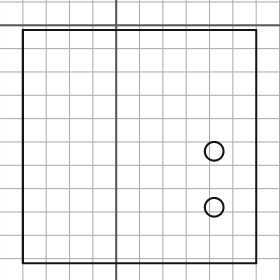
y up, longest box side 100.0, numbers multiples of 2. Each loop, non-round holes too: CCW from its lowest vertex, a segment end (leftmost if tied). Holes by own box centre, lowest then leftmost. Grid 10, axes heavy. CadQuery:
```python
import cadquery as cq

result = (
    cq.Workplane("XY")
    .moveTo(-40.0, -102.0)
    .lineTo(60.0, -102.0)
    .lineTo(60.0, -2.0)
    .lineTo(-40.0, -2.0)
    .close()
    .moveTo(42.0, -78.0)
    .circle(4.0)
    .moveTo(42.0, -54.0)
    .circle(4.0)
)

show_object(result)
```